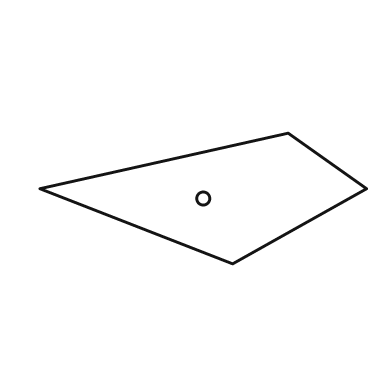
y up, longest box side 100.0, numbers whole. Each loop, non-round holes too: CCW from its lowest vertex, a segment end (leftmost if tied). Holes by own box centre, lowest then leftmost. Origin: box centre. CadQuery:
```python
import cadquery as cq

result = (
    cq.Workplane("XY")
    .moveTo(9.0, -20.0)
    .lineTo(50.0, 3.0)
    .lineTo(26.0, 20.0)
    .lineTo(-50.0, 3.0)
    .close()
    .moveTo(0.0, 0.0)
    .circle(2.0)
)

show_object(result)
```